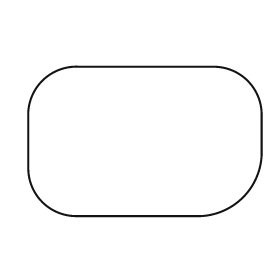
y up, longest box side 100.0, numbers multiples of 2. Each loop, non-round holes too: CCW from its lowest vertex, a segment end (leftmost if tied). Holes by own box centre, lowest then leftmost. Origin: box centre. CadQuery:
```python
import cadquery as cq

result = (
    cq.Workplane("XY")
    .moveTo(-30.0, -32.0)
    .lineTo(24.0, -32.0)
    .threePointArc((42.0, -24.0), (50.0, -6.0))
    .lineTo(50.0, 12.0)
    .threePointArc((44.0, 26.0), (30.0, 32.0))
    .lineTo(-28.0, 32.0)
    .threePointArc((-44.0, 26.0), (-50.0, 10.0))
    .lineTo(-50.0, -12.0)
    .threePointArc((-44.0, -26.0), (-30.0, -32.0))
    .close()
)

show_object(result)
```